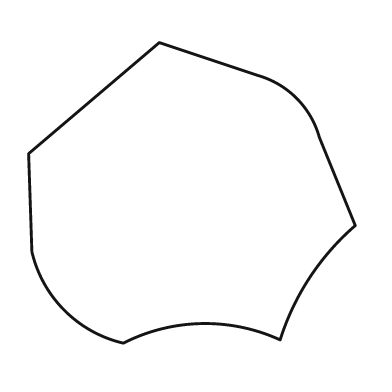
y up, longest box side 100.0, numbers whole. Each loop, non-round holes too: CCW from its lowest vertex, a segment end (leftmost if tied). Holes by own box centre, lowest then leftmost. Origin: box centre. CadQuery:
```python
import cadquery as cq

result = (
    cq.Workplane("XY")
    .moveTo(-21.0, -46.0)
    .threePointArc((3.0, -40.0), (27.0, -45.0))
    .threePointArc((36.0, -26.0), (50.0, -10.0))
    .lineTo(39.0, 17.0)
    .threePointArc((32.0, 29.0), (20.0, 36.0))
    .lineTo(-10.0, 46.0)
    .lineTo(-50.0, 12.0)
    .lineTo(-49.0, -18.0)
    .threePointArc((-39.0, -36.0), (-21.0, -46.0))
    .close()
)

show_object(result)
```